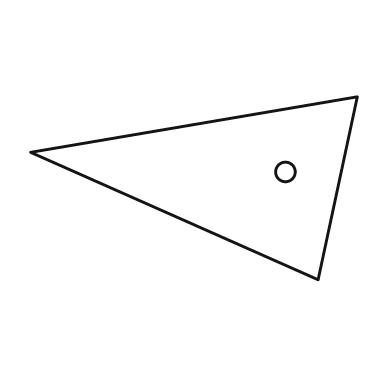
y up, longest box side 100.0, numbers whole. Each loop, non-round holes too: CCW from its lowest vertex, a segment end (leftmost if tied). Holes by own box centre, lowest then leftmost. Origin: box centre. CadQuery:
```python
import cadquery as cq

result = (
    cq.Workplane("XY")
    .moveTo(38.0, -28.0)
    .lineTo(50.0, 28.0)
    .lineTo(-50.0, 11.0)
    .close()
    .moveTo(28.0, 5.0)
    .circle(3.0)
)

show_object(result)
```